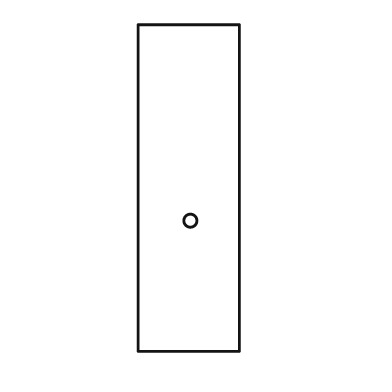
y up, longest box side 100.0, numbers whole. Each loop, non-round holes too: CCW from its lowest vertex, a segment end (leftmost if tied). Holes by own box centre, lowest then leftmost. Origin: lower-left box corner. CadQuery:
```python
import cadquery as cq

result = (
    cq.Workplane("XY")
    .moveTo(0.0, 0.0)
    .lineTo(31.0, 0.0)
    .lineTo(31.0, 100.0)
    .lineTo(0.0, 100.0)
    .close()
    .moveTo(16.0, 40.0)
    .circle(2.0)
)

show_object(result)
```